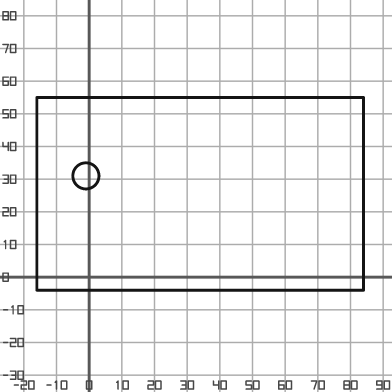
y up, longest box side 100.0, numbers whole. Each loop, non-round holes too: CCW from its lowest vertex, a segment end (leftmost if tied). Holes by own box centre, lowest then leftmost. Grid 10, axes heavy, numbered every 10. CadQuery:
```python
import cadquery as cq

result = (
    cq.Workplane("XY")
    .moveTo(-16.0, -4.0)
    .lineTo(84.0, -4.0)
    .lineTo(84.0, 55.0)
    .lineTo(-16.0, 55.0)
    .close()
    .moveTo(-1.0, 31.0)
    .circle(4.0)
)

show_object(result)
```